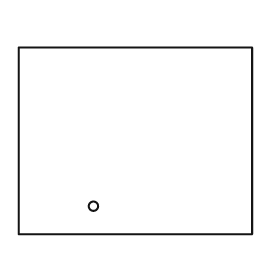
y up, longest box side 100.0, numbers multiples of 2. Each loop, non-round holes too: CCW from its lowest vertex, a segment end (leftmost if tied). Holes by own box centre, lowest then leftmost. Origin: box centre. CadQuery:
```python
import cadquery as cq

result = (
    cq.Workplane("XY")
    .moveTo(-50.0, -40.0)
    .lineTo(50.0, -40.0)
    .lineTo(50.0, 40.0)
    .lineTo(-50.0, 40.0)
    .close()
    .moveTo(-18.0, -28.0)
    .circle(2.0)
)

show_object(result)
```